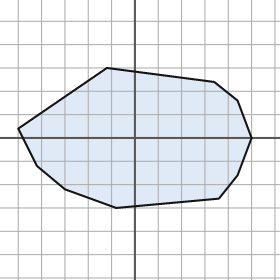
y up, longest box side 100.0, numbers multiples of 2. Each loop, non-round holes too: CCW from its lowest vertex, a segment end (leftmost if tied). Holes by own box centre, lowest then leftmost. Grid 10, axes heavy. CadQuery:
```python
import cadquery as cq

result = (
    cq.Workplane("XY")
    .moveTo(-8.0, -30.0)
    .lineTo(36.0, -26.0)
    .lineTo(44.0, -16.0)
    .lineTo(50.0, 0.0)
    .lineTo(44.0, 16.0)
    .lineTo(34.0, 24.0)
    .lineTo(-12.0, 30.0)
    .lineTo(-50.0, 4.0)
    .lineTo(-42.0, -12.0)
    .lineTo(-30.0, -22.0)
    .close()
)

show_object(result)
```